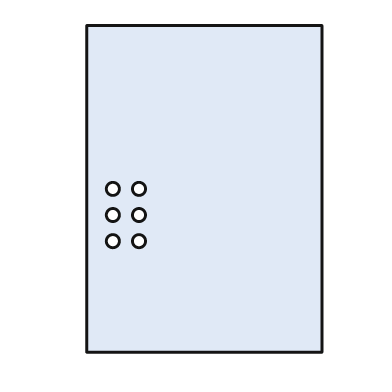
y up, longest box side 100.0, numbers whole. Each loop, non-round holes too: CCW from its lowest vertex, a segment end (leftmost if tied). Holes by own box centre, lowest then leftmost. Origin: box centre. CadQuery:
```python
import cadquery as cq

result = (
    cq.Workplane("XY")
    .moveTo(-36.0, -50.0)
    .lineTo(36.0, -50.0)
    .lineTo(36.0, 50.0)
    .lineTo(-36.0, 50.0)
    .close()
    .moveTo(-28.0, -16.0)
    .circle(2.0)
    .moveTo(-20.0, -16.0)
    .circle(2.0)
    .moveTo(-28.0, -8.0)
    .circle(2.0)
    .moveTo(-20.0, -8.0)
    .circle(2.0)
    .moveTo(-28.0, 0.0)
    .circle(2.0)
    .moveTo(-20.0, 0.0)
    .circle(2.0)
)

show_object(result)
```